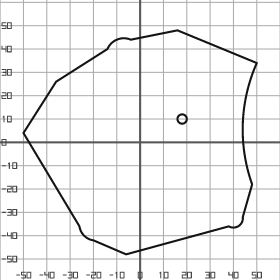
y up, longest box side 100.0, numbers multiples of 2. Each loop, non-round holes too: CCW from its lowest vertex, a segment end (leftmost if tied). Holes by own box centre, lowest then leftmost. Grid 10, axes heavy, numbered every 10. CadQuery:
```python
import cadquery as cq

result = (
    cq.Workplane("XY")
    .moveTo(-6.0, -48.0)
    .lineTo(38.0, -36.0)
    .threePointArc((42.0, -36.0), (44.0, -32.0))
    .lineTo(48.0, -18.0)
    .threePointArc((44.0, 8.0), (50.0, 34.0))
    .lineTo(16.0, 48.0)
    .lineTo(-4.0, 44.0)
    .threePointArc((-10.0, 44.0), (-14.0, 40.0))
    .lineTo(-36.0, 26.0)
    .lineTo(-50.0, 4.0)
    .lineTo(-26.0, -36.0)
    .threePointArc((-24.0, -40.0), (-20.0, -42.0))
    .close()
    .moveTo(18.0, 10.0)
    .circle(2.0)
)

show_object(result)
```